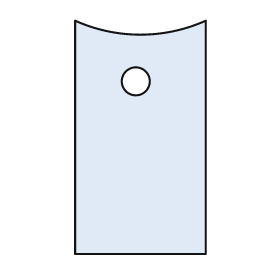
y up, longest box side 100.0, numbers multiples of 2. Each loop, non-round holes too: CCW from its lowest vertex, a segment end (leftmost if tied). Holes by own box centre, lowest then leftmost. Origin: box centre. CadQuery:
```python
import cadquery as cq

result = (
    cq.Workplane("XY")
    .moveTo(-28.0, -50.0)
    .lineTo(28.0, -50.0)
    .lineTo(28.0, 50.0)
    .threePointArc((0.0, 44.0), (-28.0, 50.0))
    .close()
    .moveTo(-2.0, 24.0)
    .circle(6.0)
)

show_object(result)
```